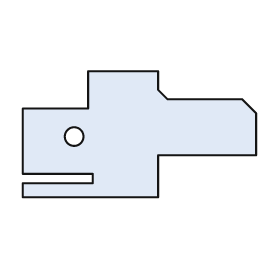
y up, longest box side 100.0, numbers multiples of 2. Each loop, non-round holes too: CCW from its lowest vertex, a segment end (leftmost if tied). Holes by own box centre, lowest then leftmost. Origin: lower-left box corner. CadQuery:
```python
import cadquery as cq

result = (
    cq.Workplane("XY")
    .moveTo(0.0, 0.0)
    .lineTo(58.0, 0.0)
    .lineTo(58.0, 18.0)
    .lineTo(100.0, 18.0)
    .lineTo(100.0, 36.0)
    .lineTo(94.0, 42.0)
    .lineTo(62.0, 42.0)
    .lineTo(58.0, 46.0)
    .lineTo(58.0, 54.0)
    .lineTo(28.0, 54.0)
    .lineTo(28.0, 38.0)
    .lineTo(0.0, 38.0)
    .lineTo(0.0, 10.0)
    .lineTo(30.0, 10.0)
    .lineTo(30.0, 6.0)
    .lineTo(0.0, 6.0)
    .close()
    .moveTo(22.0, 26.0)
    .circle(4.0)
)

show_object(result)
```